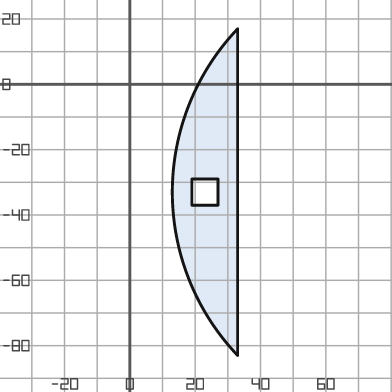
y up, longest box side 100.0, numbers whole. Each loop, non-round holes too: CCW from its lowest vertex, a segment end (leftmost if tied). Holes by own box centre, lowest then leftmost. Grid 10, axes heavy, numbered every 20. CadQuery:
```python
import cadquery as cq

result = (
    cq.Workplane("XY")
    .moveTo(33.0, -83.0)
    .lineTo(33.0, 17.0)
    .threePointArc((13.0, -33.0), (33.0, -83.0))
    .close()
    .moveTo(19.0, -37.0)
    .lineTo(27.0, -37.0)
    .lineTo(27.0, -29.0)
    .lineTo(19.0, -29.0)
    .close()
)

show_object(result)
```